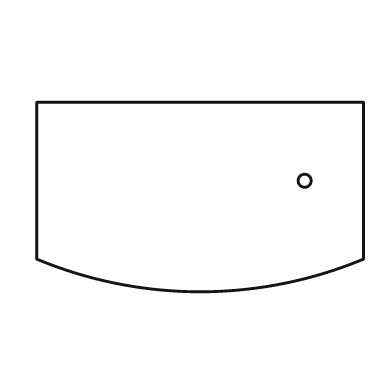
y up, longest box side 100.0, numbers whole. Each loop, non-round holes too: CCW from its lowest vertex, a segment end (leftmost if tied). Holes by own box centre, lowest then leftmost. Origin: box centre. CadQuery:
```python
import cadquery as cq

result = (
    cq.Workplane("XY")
    .moveTo(-50.0, -19.0)
    .threePointArc((0.0, -29.0), (50.0, -19.0))
    .lineTo(50.0, 29.0)
    .lineTo(-50.0, 29.0)
    .close()
    .moveTo(32.0, 5.0)
    .circle(2.0)
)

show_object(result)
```